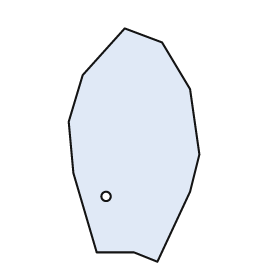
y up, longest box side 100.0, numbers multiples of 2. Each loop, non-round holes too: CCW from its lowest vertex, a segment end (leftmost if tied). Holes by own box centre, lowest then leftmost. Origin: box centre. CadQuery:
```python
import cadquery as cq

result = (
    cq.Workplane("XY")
    .moveTo(10.0, -50.0)
    .lineTo(24.0, -20.0)
    .lineTo(28.0, -4.0)
    .lineTo(24.0, 24.0)
    .lineTo(12.0, 44.0)
    .lineTo(-4.0, 50.0)
    .lineTo(-22.0, 30.0)
    .lineTo(-28.0, 10.0)
    .lineTo(-26.0, -12.0)
    .lineTo(-16.0, -46.0)
    .lineTo(0.0, -46.0)
    .close()
    .moveTo(-12.0, -22.0)
    .circle(2.0)
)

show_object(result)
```